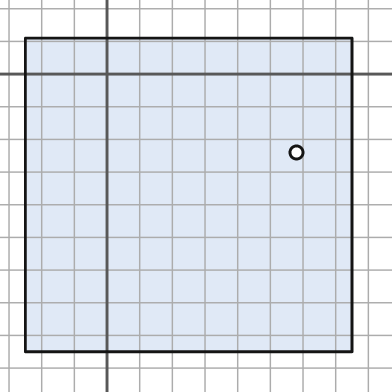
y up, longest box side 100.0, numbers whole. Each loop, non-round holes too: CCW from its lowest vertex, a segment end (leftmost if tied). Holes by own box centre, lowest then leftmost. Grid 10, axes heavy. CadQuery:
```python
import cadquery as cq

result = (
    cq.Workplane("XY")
    .moveTo(-25.0, -85.0)
    .lineTo(75.0, -85.0)
    .lineTo(75.0, 11.0)
    .lineTo(-25.0, 11.0)
    .close()
    .moveTo(58.0, -24.0)
    .circle(2.0)
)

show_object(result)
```